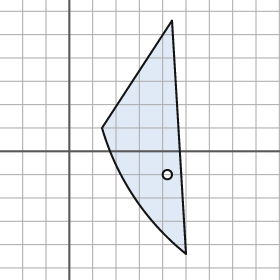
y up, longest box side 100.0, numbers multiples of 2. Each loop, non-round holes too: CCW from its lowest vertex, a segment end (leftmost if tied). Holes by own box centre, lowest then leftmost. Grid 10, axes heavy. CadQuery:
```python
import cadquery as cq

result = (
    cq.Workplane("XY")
    .moveTo(50.0, -44.0)
    .lineTo(44.0, 56.0)
    .lineTo(14.0, 10.0)
    .threePointArc((28.0, -20.0), (50.0, -44.0))
    .close()
    .moveTo(42.0, -10.0)
    .circle(2.0)
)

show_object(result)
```